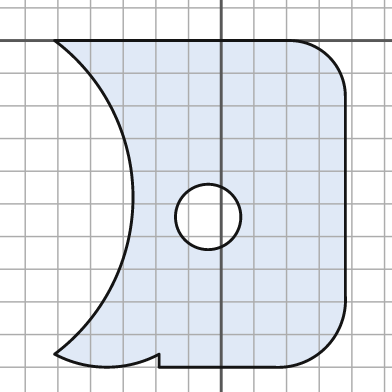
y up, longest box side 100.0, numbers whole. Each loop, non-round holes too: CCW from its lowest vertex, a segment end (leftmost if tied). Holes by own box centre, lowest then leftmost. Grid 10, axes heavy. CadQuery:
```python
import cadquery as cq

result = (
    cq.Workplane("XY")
    .moveTo(-19.0, -100.0)
    .lineTo(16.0, -100.0)
    .threePointArc((32.0, -94.0), (38.0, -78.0))
    .lineTo(38.0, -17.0)
    .threePointArc((33.0, -5.0), (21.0, 0.0))
    .lineTo(-51.0, 0.0)
    .threePointArc((-27.0, -48.0), (-51.0, -96.0))
    .threePointArc((-35.0, -100.0), (-19.0, -96.0))
    .close()
    .moveTo(-4.0, -54.0)
    .circle(10.0)
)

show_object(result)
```